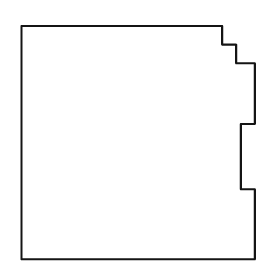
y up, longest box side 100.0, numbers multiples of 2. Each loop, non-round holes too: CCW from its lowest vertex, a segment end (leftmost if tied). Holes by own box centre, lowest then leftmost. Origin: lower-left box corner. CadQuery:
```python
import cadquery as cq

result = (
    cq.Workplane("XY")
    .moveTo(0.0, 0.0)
    .lineTo(100.0, 0.0)
    .lineTo(100.0, 30.0)
    .lineTo(94.0, 30.0)
    .lineTo(94.0, 58.0)
    .lineTo(100.0, 58.0)
    .lineTo(100.0, 84.0)
    .lineTo(92.0, 84.0)
    .lineTo(92.0, 92.0)
    .lineTo(86.0, 92.0)
    .lineTo(86.0, 100.0)
    .lineTo(0.0, 100.0)
    .close()
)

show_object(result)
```